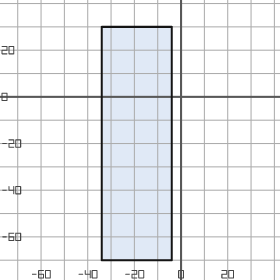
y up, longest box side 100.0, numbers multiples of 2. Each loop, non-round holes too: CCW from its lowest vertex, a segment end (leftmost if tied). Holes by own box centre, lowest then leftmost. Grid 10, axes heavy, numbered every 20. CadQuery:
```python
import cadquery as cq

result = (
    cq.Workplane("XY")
    .moveTo(-34.0, -70.0)
    .lineTo(-4.0, -70.0)
    .lineTo(-4.0, 30.0)
    .lineTo(-34.0, 30.0)
    .close()
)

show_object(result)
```